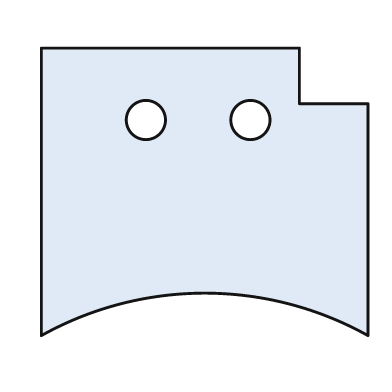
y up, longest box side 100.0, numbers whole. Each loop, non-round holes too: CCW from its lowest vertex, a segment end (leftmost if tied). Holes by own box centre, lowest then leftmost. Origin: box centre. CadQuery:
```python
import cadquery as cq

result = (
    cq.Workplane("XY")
    .moveTo(-50.0, -44.0)
    .threePointArc((0.0, -31.0), (50.0, -44.0))
    .lineTo(50.0, 27.0)
    .lineTo(29.0, 27.0)
    .lineTo(29.0, 44.0)
    .lineTo(-50.0, 44.0)
    .close()
    .moveTo(-18.0, 22.0)
    .circle(6.0)
    .moveTo(14.0, 22.0)
    .circle(6.0)
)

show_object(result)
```